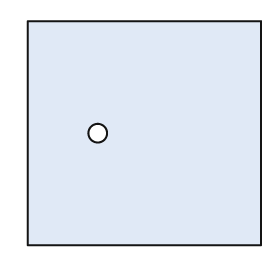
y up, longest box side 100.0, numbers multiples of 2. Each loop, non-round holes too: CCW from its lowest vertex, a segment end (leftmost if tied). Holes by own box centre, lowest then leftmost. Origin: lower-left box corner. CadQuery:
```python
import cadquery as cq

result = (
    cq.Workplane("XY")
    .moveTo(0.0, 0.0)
    .lineTo(100.0, 0.0)
    .lineTo(100.0, 96.0)
    .lineTo(0.0, 96.0)
    .close()
    .moveTo(30.0, 48.0)
    .circle(4.0)
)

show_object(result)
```